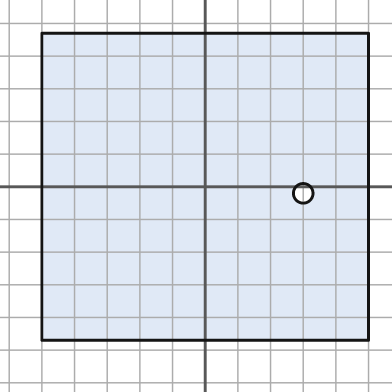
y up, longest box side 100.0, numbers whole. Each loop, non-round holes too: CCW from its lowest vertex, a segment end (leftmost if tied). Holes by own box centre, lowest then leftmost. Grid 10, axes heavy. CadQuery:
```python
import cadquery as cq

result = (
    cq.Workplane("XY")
    .moveTo(-50.0, -47.0)
    .lineTo(50.0, -47.0)
    .lineTo(50.0, 47.0)
    .lineTo(-50.0, 47.0)
    .close()
    .moveTo(30.0, -2.0)
    .circle(3.0)
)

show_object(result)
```